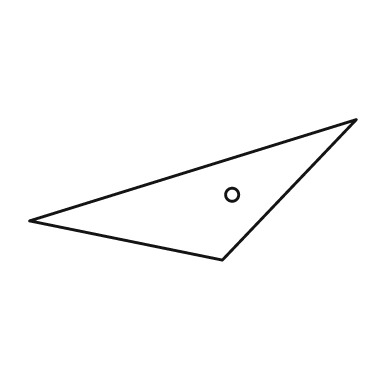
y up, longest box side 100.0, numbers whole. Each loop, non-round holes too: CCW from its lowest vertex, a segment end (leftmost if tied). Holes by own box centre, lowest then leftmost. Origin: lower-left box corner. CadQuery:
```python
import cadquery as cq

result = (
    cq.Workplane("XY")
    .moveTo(59.0, 0.0)
    .lineTo(100.0, 43.0)
    .lineTo(0.0, 12.0)
    .close()
    .moveTo(62.0, 20.0)
    .circle(2.0)
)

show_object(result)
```